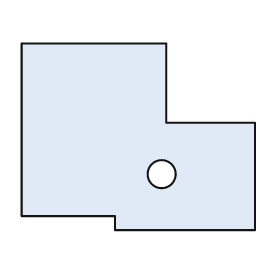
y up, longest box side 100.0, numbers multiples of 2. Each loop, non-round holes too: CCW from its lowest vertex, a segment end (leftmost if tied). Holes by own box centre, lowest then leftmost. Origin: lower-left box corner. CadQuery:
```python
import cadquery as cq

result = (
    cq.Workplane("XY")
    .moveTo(40.0, 0.0)
    .lineTo(100.0, 0.0)
    .lineTo(100.0, 46.0)
    .lineTo(62.0, 46.0)
    .lineTo(62.0, 80.0)
    .lineTo(0.0, 80.0)
    .lineTo(0.0, 6.0)
    .lineTo(40.0, 6.0)
    .close()
    .moveTo(60.0, 24.0)
    .circle(6.0)
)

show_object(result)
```